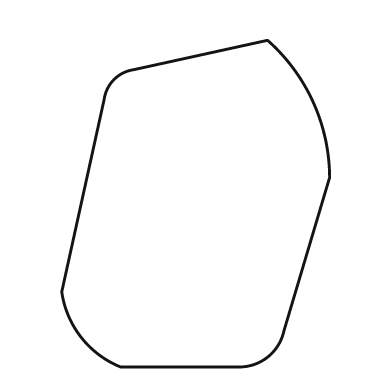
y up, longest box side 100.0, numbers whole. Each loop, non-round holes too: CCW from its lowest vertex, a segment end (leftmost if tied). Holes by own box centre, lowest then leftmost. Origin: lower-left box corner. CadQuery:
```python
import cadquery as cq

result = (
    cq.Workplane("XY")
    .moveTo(18.0, 0.0)
    .lineTo(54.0, 0.0)
    .threePointArc((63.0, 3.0), (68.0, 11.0))
    .lineTo(82.0, 58.0)
    .threePointArc((77.0, 81.0), (63.0, 100.0))
    .lineTo(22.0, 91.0)
    .threePointArc((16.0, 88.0), (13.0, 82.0))
    .lineTo(0.0, 23.0)
    .threePointArc((6.0, 9.0), (18.0, 0.0))
    .close()
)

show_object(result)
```